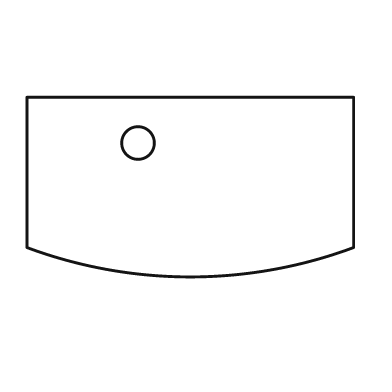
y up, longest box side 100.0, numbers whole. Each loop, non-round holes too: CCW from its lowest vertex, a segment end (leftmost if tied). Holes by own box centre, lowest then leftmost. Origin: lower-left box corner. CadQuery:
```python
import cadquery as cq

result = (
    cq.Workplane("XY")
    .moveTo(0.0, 9.0)
    .threePointArc((50.0, 0.0), (100.0, 9.0))
    .lineTo(100.0, 55.0)
    .lineTo(0.0, 55.0)
    .close()
    .moveTo(34.0, 41.0)
    .circle(5.0)
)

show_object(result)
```